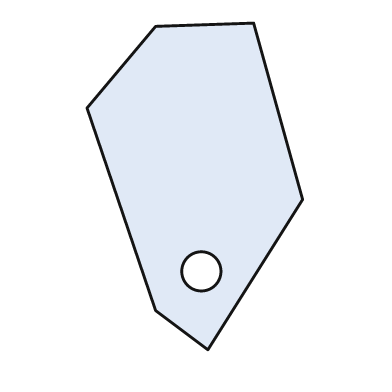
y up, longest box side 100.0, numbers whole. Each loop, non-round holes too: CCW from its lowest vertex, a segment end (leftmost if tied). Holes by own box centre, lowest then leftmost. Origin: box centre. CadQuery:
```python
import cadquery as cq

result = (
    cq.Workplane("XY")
    .moveTo(4.0, -50.0)
    .lineTo(33.0, -4.0)
    .lineTo(18.0, 50.0)
    .lineTo(-12.0, 49.0)
    .lineTo(-33.0, 24.0)
    .lineTo(-12.0, -38.0)
    .close()
    .moveTo(2.0, -26.0)
    .circle(6.0)
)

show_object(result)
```